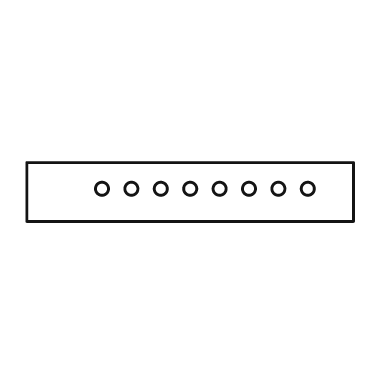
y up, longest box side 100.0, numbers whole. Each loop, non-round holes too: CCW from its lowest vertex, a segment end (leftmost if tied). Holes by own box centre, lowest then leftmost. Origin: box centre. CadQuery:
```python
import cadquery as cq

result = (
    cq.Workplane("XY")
    .moveTo(-50.0, -9.0)
    .lineTo(50.0, -9.0)
    .lineTo(50.0, 9.0)
    .lineTo(-50.0, 9.0)
    .close()
    .moveTo(-27.0, 1.0)
    .circle(2.0)
    .moveTo(-18.0, 1.0)
    .circle(2.0)
    .moveTo(-9.0, 1.0)
    .circle(2.0)
    .moveTo(0.0, 1.0)
    .circle(2.0)
    .moveTo(9.0, 1.0)
    .circle(2.0)
    .moveTo(18.0, 1.0)
    .circle(2.0)
    .moveTo(27.0, 1.0)
    .circle(2.0)
    .moveTo(36.0, 1.0)
    .circle(2.0)
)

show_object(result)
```